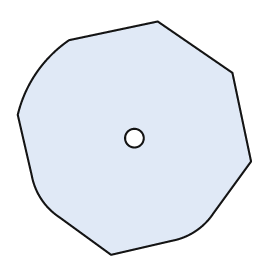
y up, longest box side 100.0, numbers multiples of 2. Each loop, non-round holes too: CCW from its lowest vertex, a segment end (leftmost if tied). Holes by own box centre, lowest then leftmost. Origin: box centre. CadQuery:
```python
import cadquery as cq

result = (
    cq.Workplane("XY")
    .moveTo(-10.0, -50.0)
    .lineTo(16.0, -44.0)
    .threePointArc((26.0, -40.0), (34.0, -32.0))
    .lineTo(50.0, -10.0)
    .lineTo(42.0, 28.0)
    .lineTo(10.0, 50.0)
    .lineTo(-28.0, 42.0)
    .threePointArc((-42.0, 28.0), (-50.0, 10.0))
    .lineTo(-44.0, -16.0)
    .threePointArc((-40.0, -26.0), (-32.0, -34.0))
    .close()
    .moveTo(0.0, 0.0)
    .circle(4.0)
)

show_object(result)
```